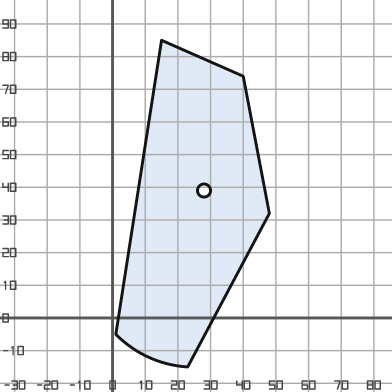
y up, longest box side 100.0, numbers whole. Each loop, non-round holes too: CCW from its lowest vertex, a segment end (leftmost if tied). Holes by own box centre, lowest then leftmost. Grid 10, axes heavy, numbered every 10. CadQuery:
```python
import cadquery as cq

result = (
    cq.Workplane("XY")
    .moveTo(23.0, -15.0)
    .lineTo(48.0, 32.0)
    .lineTo(40.0, 74.0)
    .lineTo(15.0, 85.0)
    .lineTo(1.0, -5.0)
    .threePointArc((11.0, -12.0), (23.0, -15.0))
    .close()
    .moveTo(28.0, 39.0)
    .circle(2.0)
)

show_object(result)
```